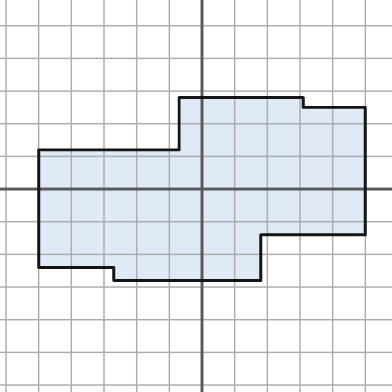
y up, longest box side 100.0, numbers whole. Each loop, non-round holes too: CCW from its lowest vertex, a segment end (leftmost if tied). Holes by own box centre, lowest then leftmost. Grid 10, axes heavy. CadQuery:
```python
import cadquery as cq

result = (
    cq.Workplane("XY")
    .moveTo(-27.0, -28.0)
    .lineTo(18.0, -28.0)
    .lineTo(18.0, -14.0)
    .lineTo(50.0, -14.0)
    .lineTo(50.0, 25.0)
    .lineTo(31.0, 25.0)
    .lineTo(31.0, 28.0)
    .lineTo(-7.0, 28.0)
    .lineTo(-7.0, 12.0)
    .lineTo(-50.0, 12.0)
    .lineTo(-50.0, -24.0)
    .lineTo(-27.0, -24.0)
    .close()
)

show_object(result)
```